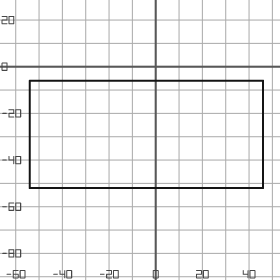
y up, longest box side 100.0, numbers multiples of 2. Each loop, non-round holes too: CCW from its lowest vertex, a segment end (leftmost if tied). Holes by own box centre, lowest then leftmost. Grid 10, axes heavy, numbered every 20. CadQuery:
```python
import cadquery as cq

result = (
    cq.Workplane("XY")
    .moveTo(-54.0, -52.0)
    .lineTo(46.0, -52.0)
    .lineTo(46.0, -6.0)
    .lineTo(-54.0, -6.0)
    .close()
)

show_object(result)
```